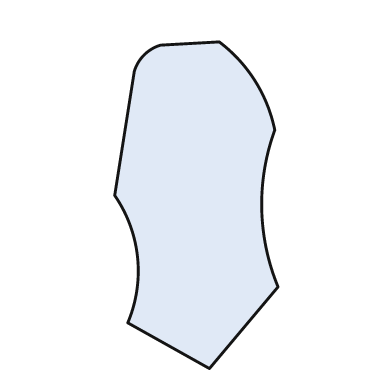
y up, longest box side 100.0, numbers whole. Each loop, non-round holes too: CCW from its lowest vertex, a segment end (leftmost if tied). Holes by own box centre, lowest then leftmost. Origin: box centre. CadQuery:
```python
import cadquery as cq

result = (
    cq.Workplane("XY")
    .moveTo(4.0, -50.0)
    .lineTo(25.0, -25.0)
    .threePointArc((20.0, -1.0), (24.0, 23.0))
    .threePointArc((18.0, 38.0), (7.0, 50.0))
    .lineTo(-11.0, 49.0)
    .threePointArc((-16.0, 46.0), (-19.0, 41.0))
    .lineTo(-25.0, 3.0)
    .threePointArc((-18.0, -16.0), (-21.0, -36.0))
    .close()
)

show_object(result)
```